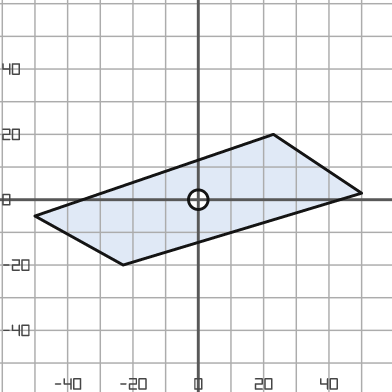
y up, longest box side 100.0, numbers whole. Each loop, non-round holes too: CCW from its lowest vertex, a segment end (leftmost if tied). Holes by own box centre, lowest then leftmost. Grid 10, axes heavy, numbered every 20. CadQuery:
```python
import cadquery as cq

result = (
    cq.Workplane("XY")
    .moveTo(-23.0, -20.0)
    .lineTo(50.0, 2.0)
    .lineTo(23.0, 20.0)
    .lineTo(-50.0, -5.0)
    .close()
    .moveTo(0.0, 0.0)
    .circle(3.0)
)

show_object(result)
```